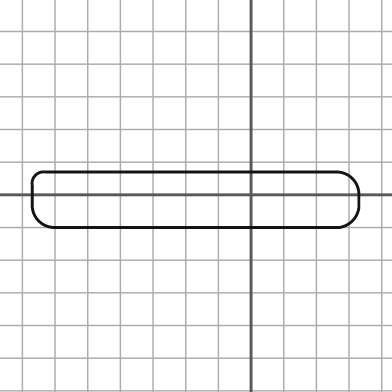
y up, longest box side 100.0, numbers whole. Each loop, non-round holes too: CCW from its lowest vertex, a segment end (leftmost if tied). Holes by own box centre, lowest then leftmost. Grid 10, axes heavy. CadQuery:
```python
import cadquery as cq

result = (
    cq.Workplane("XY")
    .moveTo(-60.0, -10.0)
    .lineTo(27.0, -10.0)
    .threePointArc((31.0, -8.0), (33.0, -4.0))
    .lineTo(33.0, 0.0)
    .threePointArc((31.0, 5.0), (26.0, 7.0))
    .lineTo(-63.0, 7.0)
    .threePointArc((-66.0, 6.0), (-67.0, 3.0))
    .lineTo(-67.0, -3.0)
    .threePointArc((-65.0, -8.0), (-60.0, -10.0))
    .close()
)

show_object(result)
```